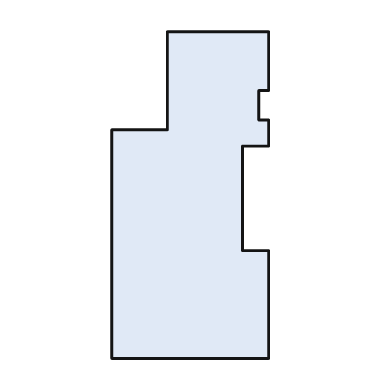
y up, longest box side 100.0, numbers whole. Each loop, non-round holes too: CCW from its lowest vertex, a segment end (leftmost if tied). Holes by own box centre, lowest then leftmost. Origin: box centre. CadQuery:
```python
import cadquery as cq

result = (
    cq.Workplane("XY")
    .moveTo(-24.0, -50.0)
    .lineTo(24.0, -50.0)
    .lineTo(24.0, -17.0)
    .lineTo(16.0, -17.0)
    .lineTo(16.0, 15.0)
    .lineTo(24.0, 15.0)
    .lineTo(24.0, 23.0)
    .lineTo(21.0, 23.0)
    .lineTo(21.0, 32.0)
    .lineTo(24.0, 32.0)
    .lineTo(24.0, 50.0)
    .lineTo(-7.0, 50.0)
    .lineTo(-7.0, 20.0)
    .lineTo(-24.0, 20.0)
    .close()
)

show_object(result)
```